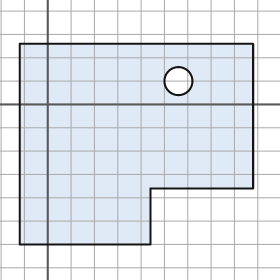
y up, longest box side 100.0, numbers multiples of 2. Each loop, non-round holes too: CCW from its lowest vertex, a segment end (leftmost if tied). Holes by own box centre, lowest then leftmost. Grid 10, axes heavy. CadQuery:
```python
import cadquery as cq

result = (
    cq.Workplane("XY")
    .moveTo(-12.0, -60.0)
    .lineTo(44.0, -60.0)
    .lineTo(44.0, -36.0)
    .lineTo(88.0, -36.0)
    .lineTo(88.0, 26.0)
    .lineTo(-12.0, 26.0)
    .close()
    .moveTo(56.0, 10.0)
    .circle(6.0)
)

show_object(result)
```